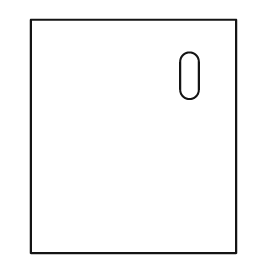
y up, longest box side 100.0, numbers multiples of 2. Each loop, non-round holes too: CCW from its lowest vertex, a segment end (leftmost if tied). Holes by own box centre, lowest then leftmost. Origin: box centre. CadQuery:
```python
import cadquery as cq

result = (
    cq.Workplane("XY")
    .moveTo(-44.0, -50.0)
    .lineTo(44.0, -50.0)
    .lineTo(44.0, 50.0)
    .lineTo(-44.0, 50.0)
    .close()
    .moveTo(20.0, 20.0)
    .threePointArc((24.0, 16.0), (28.0, 20.0))
    .lineTo(28.0, 32.0)
    .threePointArc((24.0, 36.0), (20.0, 32.0))
    .close()
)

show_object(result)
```